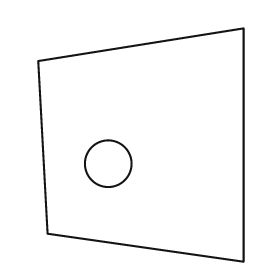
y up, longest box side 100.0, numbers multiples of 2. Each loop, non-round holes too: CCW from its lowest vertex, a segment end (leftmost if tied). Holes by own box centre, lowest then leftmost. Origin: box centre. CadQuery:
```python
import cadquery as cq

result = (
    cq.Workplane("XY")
    .moveTo(44.0, -50.0)
    .lineTo(44.0, 50.0)
    .lineTo(-44.0, 36.0)
    .lineTo(-40.0, -38.0)
    .close()
    .moveTo(-14.0, -8.0)
    .circle(10.0)
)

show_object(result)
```